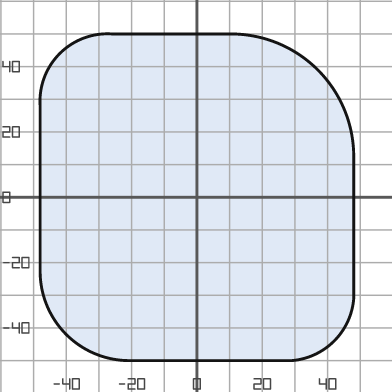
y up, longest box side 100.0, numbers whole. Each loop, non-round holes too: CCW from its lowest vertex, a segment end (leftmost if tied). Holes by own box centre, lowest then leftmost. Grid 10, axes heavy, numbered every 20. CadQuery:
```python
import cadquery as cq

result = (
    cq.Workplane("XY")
    .moveTo(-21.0, -50.0)
    .lineTo(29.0, -50.0)
    .threePointArc((42.0, -44.0), (48.0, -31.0))
    .lineTo(48.0, 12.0)
    .threePointArc((37.0, 39.0), (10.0, 50.0))
    .lineTo(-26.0, 50.0)
    .threePointArc((-42.0, 44.0), (-48.0, 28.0))
    .lineTo(-48.0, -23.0)
    .threePointArc((-40.0, -42.0), (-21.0, -50.0))
    .close()
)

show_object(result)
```